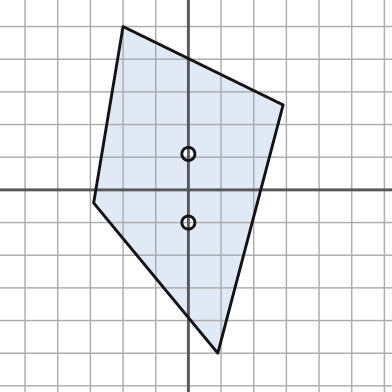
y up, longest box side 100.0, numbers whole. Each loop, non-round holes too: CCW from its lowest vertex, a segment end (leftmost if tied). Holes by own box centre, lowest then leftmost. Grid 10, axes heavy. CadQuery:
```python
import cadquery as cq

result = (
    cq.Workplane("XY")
    .moveTo(9.0, -50.0)
    .lineTo(29.0, 26.0)
    .lineTo(-20.0, 50.0)
    .lineTo(-29.0, -4.0)
    .close()
    .moveTo(0.0, -10.0)
    .circle(2.0)
    .moveTo(0.0, 11.0)
    .circle(2.0)
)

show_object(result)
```